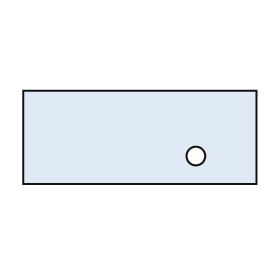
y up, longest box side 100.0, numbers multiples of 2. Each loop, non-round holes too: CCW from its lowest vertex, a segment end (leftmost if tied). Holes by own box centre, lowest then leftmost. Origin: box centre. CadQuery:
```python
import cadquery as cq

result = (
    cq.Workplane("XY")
    .moveTo(-50.0, -20.0)
    .lineTo(50.0, -20.0)
    .lineTo(50.0, 20.0)
    .lineTo(-50.0, 20.0)
    .close()
    .moveTo(24.0, -8.0)
    .circle(4.0)
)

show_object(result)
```